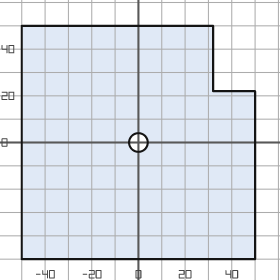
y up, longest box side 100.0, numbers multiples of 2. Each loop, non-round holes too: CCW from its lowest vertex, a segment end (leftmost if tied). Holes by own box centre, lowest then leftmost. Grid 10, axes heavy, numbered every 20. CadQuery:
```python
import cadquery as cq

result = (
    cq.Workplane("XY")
    .moveTo(-50.0, -50.0)
    .lineTo(50.0, -50.0)
    .lineTo(50.0, 22.0)
    .lineTo(32.0, 22.0)
    .lineTo(32.0, 50.0)
    .lineTo(-50.0, 50.0)
    .close()
    .moveTo(0.0, 0.0)
    .circle(4.0)
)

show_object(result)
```